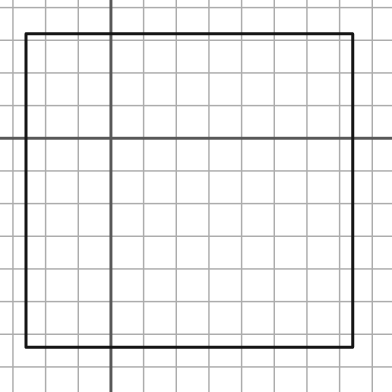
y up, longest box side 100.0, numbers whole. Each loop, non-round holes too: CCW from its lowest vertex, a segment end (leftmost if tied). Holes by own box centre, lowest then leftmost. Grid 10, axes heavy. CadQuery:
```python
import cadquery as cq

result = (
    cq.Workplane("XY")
    .moveTo(-26.0, -64.0)
    .lineTo(74.0, -64.0)
    .lineTo(74.0, 32.0)
    .lineTo(-26.0, 32.0)
    .close()
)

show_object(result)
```